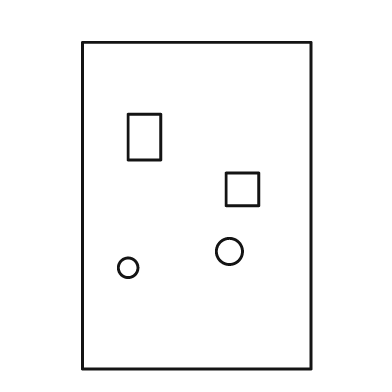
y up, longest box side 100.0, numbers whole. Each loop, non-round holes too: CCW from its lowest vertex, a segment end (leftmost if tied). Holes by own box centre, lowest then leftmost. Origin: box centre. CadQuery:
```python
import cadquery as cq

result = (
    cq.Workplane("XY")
    .moveTo(-35.0, -50.0)
    .lineTo(35.0, -50.0)
    .lineTo(35.0, 50.0)
    .lineTo(-35.0, 50.0)
    .close()
    .moveTo(-21.0, -19.0)
    .circle(3.0)
    .moveTo(10.0, -14.0)
    .circle(4.0)
    .moveTo(9.0, 0.0)
    .lineTo(19.0, 0.0)
    .lineTo(19.0, 10.0)
    .lineTo(9.0, 10.0)
    .close()
    .moveTo(-21.0, 14.0)
    .lineTo(-11.0, 14.0)
    .lineTo(-11.0, 28.0)
    .lineTo(-21.0, 28.0)
    .close()
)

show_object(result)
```